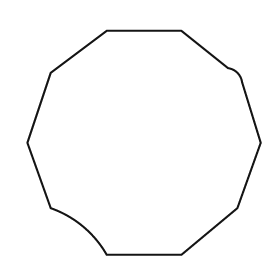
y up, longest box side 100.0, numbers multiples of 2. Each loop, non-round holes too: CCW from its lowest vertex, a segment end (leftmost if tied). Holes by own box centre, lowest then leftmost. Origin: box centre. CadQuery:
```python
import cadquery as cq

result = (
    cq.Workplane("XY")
    .moveTo(-16.0, -48.0)
    .lineTo(16.0, -48.0)
    .lineTo(40.0, -28.0)
    .lineTo(50.0, 0.0)
    .lineTo(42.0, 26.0)
    .threePointArc((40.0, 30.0), (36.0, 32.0))
    .lineTo(16.0, 48.0)
    .lineTo(-16.0, 48.0)
    .lineTo(-40.0, 30.0)
    .lineTo(-50.0, 0.0)
    .lineTo(-40.0, -28.0)
    .threePointArc((-26.0, -36.0), (-16.0, -48.0))
    .close()
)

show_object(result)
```